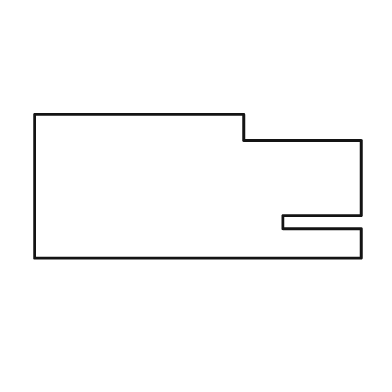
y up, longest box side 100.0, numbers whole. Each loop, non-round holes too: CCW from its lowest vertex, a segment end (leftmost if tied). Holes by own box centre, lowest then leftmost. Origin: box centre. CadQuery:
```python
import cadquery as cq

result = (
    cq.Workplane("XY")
    .moveTo(-50.0, -22.0)
    .lineTo(50.0, -22.0)
    .lineTo(50.0, -13.0)
    .lineTo(26.0, -13.0)
    .lineTo(26.0, -9.0)
    .lineTo(50.0, -9.0)
    .lineTo(50.0, 14.0)
    .lineTo(14.0, 14.0)
    .lineTo(14.0, 22.0)
    .lineTo(-50.0, 22.0)
    .close()
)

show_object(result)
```